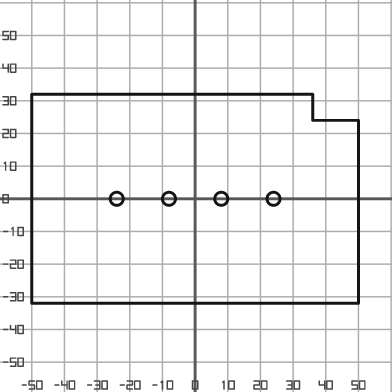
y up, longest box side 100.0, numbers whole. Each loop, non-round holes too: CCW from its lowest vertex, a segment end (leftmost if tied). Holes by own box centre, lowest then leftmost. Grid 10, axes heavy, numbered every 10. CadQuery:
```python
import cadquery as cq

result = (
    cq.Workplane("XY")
    .moveTo(-50.0, -32.0)
    .lineTo(50.0, -32.0)
    .lineTo(50.0, 24.0)
    .lineTo(36.0, 24.0)
    .lineTo(36.0, 32.0)
    .lineTo(-50.0, 32.0)
    .close()
    .moveTo(-24.0, 0.0)
    .circle(2.0)
    .moveTo(-8.0, 0.0)
    .circle(2.0)
    .moveTo(8.0, 0.0)
    .circle(2.0)
    .moveTo(24.0, 0.0)
    .circle(2.0)
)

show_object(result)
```